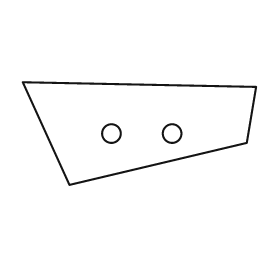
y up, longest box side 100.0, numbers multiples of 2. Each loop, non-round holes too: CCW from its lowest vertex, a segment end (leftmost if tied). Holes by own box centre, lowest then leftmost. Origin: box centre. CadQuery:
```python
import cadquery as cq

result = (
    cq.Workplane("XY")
    .moveTo(-30.0, -22.0)
    .lineTo(46.0, -4.0)
    .lineTo(50.0, 20.0)
    .lineTo(-50.0, 22.0)
    .close()
    .moveTo(-12.0, 0.0)
    .circle(4.0)
    .moveTo(14.0, 0.0)
    .circle(4.0)
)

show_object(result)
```